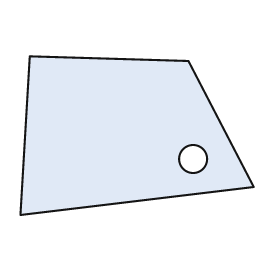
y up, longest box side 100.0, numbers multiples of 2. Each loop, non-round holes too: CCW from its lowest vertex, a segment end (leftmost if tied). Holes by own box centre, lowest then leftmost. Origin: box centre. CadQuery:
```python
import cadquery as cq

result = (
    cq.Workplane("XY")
    .moveTo(-50.0, -34.0)
    .lineTo(50.0, -22.0)
    .lineTo(22.0, 32.0)
    .lineTo(-46.0, 34.0)
    .close()
    .moveTo(24.0, -10.0)
    .circle(6.0)
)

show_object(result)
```